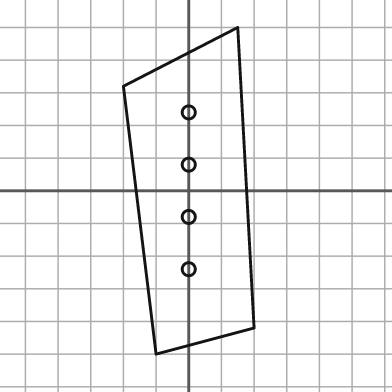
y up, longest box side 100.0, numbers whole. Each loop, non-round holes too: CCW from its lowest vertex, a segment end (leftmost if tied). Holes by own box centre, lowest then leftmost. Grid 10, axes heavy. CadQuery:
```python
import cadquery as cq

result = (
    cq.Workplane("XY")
    .moveTo(-10.0, -50.0)
    .lineTo(20.0, -42.0)
    .lineTo(15.0, 50.0)
    .lineTo(-20.0, 32.0)
    .close()
    .moveTo(0.0, -24.0)
    .circle(2.0)
    .moveTo(0.0, -8.0)
    .circle(2.0)
    .moveTo(0.0, 8.0)
    .circle(2.0)
    .moveTo(0.0, 24.0)
    .circle(2.0)
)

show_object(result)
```